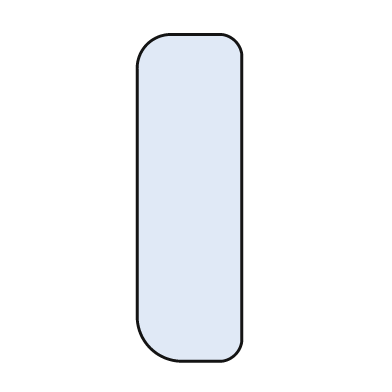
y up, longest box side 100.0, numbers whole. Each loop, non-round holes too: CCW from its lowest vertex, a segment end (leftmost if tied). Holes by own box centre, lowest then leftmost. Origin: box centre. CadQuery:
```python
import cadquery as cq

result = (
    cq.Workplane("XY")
    .moveTo(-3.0, -50.0)
    .lineTo(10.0, -50.0)
    .threePointArc((14.0, -48.0), (16.0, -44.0))
    .lineTo(16.0, 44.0)
    .threePointArc((14.0, 48.0), (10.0, 50.0))
    .lineTo(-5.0, 50.0)
    .threePointArc((-13.0, 47.0), (-16.0, 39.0))
    .lineTo(-16.0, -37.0)
    .threePointArc((-12.0, -46.0), (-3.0, -50.0))
    .close()
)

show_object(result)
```